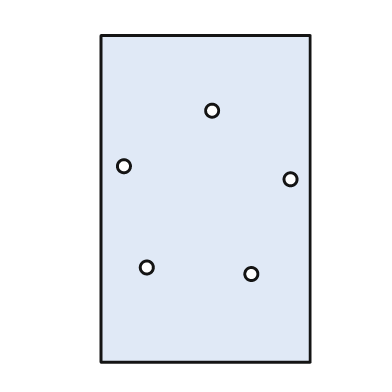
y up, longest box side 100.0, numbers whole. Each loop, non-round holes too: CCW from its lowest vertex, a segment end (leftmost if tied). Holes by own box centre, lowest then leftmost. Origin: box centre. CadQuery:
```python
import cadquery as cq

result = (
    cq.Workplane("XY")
    .moveTo(-32.0, -50.0)
    .lineTo(32.0, -50.0)
    .lineTo(32.0, 50.0)
    .lineTo(-32.0, 50.0)
    .close()
    .moveTo(14.0, -23.0)
    .circle(2.0)
    .moveTo(-18.0, -21.0)
    .circle(2.0)
    .moveTo(26.0, 6.0)
    .circle(2.0)
    .moveTo(-25.0, 10.0)
    .circle(2.0)
    .moveTo(2.0, 27.0)
    .circle(2.0)
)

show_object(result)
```